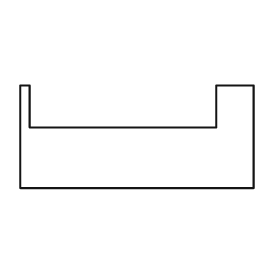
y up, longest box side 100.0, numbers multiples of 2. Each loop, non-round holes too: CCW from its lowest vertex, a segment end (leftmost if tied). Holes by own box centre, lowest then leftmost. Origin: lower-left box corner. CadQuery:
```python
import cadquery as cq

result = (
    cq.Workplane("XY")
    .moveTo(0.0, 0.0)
    .lineTo(100.0, 0.0)
    .lineTo(100.0, 44.0)
    .lineTo(84.0, 44.0)
    .lineTo(84.0, 26.0)
    .lineTo(4.0, 26.0)
    .lineTo(4.0, 44.0)
    .lineTo(0.0, 44.0)
    .close()
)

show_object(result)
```